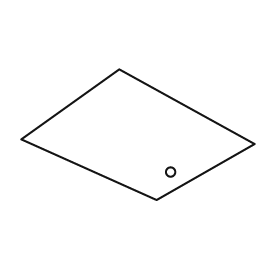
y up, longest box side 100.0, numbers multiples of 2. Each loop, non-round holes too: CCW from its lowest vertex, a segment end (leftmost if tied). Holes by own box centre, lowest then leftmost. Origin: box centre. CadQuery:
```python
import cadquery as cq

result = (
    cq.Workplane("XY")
    .moveTo(8.0, -28.0)
    .lineTo(50.0, -4.0)
    .lineTo(-8.0, 28.0)
    .lineTo(-50.0, -2.0)
    .close()
    .moveTo(14.0, -16.0)
    .circle(2.0)
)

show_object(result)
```